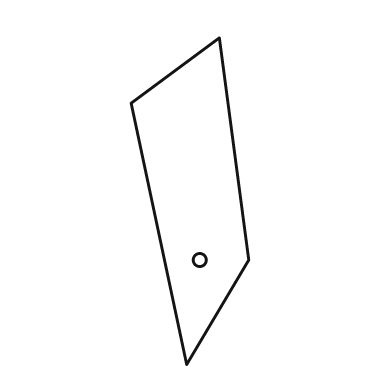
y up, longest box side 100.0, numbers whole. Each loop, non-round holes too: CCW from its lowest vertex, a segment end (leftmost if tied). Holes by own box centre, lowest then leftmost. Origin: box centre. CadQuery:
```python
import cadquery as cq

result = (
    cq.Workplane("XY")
    .moveTo(-1.0, -50.0)
    .lineTo(18.0, -18.0)
    .lineTo(9.0, 50.0)
    .lineTo(-18.0, 30.0)
    .close()
    .moveTo(3.0, -18.0)
    .circle(2.0)
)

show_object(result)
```